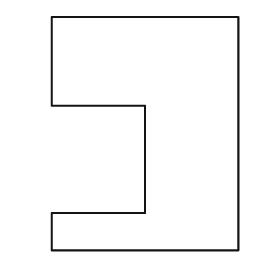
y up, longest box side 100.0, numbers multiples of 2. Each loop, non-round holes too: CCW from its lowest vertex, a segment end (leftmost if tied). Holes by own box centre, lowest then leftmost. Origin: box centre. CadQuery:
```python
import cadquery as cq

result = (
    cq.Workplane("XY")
    .moveTo(-40.0, -50.0)
    .lineTo(40.0, -50.0)
    .lineTo(40.0, 50.0)
    .lineTo(-40.0, 50.0)
    .lineTo(-40.0, 12.0)
    .lineTo(0.0, 12.0)
    .lineTo(0.0, -34.0)
    .lineTo(-40.0, -34.0)
    .close()
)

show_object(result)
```